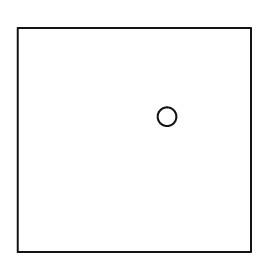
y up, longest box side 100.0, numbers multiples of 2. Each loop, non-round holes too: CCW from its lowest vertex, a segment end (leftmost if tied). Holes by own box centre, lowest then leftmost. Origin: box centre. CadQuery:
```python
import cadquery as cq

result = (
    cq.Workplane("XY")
    .moveTo(-50.0, -48.0)
    .lineTo(50.0, -48.0)
    .lineTo(50.0, 48.0)
    .lineTo(-50.0, 48.0)
    .close()
    .moveTo(14.0, 10.0)
    .circle(4.0)
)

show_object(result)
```